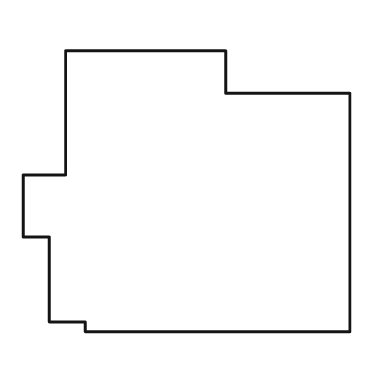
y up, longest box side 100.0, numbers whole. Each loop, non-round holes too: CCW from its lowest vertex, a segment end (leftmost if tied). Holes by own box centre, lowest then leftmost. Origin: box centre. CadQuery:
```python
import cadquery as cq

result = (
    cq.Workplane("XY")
    .moveTo(-31.0, -43.0)
    .lineTo(50.0, -43.0)
    .lineTo(50.0, 30.0)
    .lineTo(12.0, 30.0)
    .lineTo(12.0, 43.0)
    .lineTo(-37.0, 43.0)
    .lineTo(-37.0, 5.0)
    .lineTo(-50.0, 5.0)
    .lineTo(-50.0, -14.0)
    .lineTo(-42.0, -14.0)
    .lineTo(-42.0, -40.0)
    .lineTo(-31.0, -40.0)
    .close()
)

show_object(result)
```